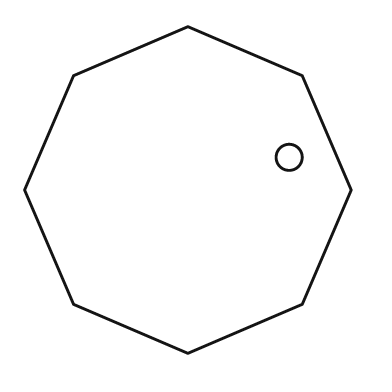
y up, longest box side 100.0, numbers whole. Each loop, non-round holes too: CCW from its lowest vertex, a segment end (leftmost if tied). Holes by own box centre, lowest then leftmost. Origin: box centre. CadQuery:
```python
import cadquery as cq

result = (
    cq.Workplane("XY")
    .moveTo(0.0, -50.0)
    .lineTo(35.0, -35.0)
    .lineTo(50.0, 0.0)
    .lineTo(35.0, 35.0)
    .lineTo(0.0, 50.0)
    .lineTo(-35.0, 35.0)
    .lineTo(-50.0, 0.0)
    .lineTo(-35.0, -35.0)
    .close()
    .moveTo(31.0, 10.0)
    .circle(4.0)
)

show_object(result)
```